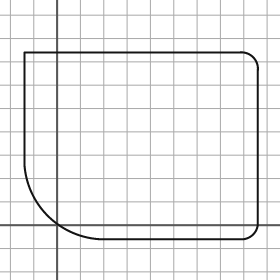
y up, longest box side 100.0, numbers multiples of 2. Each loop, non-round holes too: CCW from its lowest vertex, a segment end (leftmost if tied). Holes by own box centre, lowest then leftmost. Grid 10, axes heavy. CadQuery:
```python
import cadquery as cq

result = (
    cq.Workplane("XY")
    .moveTo(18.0, -6.0)
    .lineTo(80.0, -6.0)
    .threePointArc((84.0, -4.0), (86.0, 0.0))
    .lineTo(86.0, 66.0)
    .threePointArc((84.0, 72.0), (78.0, 74.0))
    .lineTo(-14.0, 74.0)
    .lineTo(-14.0, 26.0)
    .threePointArc((-4.0, 4.0), (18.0, -6.0))
    .close()
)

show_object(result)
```